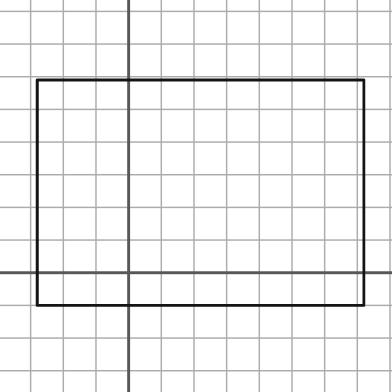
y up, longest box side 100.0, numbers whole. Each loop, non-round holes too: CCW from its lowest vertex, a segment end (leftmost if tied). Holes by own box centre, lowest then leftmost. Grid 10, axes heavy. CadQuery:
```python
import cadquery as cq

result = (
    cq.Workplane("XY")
    .moveTo(-28.0, -10.0)
    .lineTo(72.0, -10.0)
    .lineTo(72.0, 59.0)
    .lineTo(-28.0, 59.0)
    .close()
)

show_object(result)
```